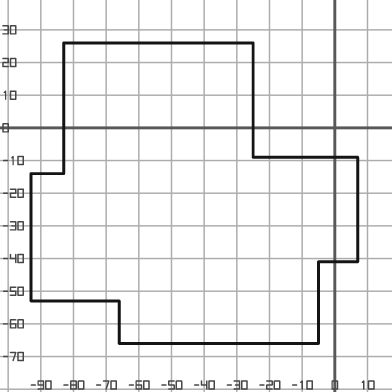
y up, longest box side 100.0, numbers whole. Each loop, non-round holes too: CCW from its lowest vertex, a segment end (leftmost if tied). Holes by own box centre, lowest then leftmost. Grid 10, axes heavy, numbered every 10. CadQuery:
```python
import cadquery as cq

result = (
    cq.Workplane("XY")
    .moveTo(-66.0, -66.0)
    .lineTo(-5.0, -66.0)
    .lineTo(-5.0, -41.0)
    .lineTo(7.0, -41.0)
    .lineTo(7.0, -9.0)
    .lineTo(-25.0, -9.0)
    .lineTo(-25.0, 26.0)
    .lineTo(-83.0, 26.0)
    .lineTo(-83.0, -14.0)
    .lineTo(-93.0, -14.0)
    .lineTo(-93.0, -53.0)
    .lineTo(-66.0, -53.0)
    .close()
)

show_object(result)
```